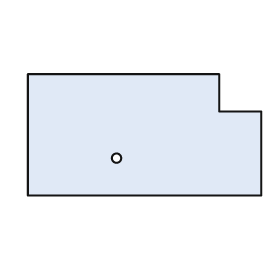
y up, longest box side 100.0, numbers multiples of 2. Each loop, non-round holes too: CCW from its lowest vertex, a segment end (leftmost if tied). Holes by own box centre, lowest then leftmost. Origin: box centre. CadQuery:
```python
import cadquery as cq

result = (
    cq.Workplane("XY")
    .moveTo(-50.0, -26.0)
    .lineTo(50.0, -26.0)
    .lineTo(50.0, 10.0)
    .lineTo(32.0, 10.0)
    .lineTo(32.0, 26.0)
    .lineTo(-50.0, 26.0)
    .close()
    .moveTo(-12.0, -10.0)
    .circle(2.0)
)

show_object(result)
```